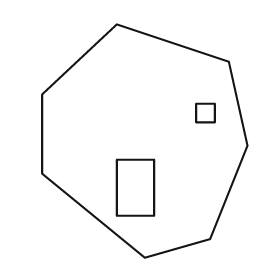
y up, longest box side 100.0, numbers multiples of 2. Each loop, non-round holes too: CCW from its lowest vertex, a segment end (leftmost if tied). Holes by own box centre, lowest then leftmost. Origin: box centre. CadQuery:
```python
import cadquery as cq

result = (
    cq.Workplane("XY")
    .moveTo(0.0, -50.0)
    .lineTo(28.0, -42.0)
    .lineTo(44.0, -2.0)
    .lineTo(36.0, 34.0)
    .lineTo(-12.0, 50.0)
    .lineTo(-44.0, 20.0)
    .lineTo(-44.0, -14.0)
    .close()
    .moveTo(-12.0, -32.0)
    .lineTo(4.0, -32.0)
    .lineTo(4.0, -8.0)
    .lineTo(-12.0, -8.0)
    .close()
    .moveTo(22.0, 8.0)
    .lineTo(30.0, 8.0)
    .lineTo(30.0, 16.0)
    .lineTo(22.0, 16.0)
    .close()
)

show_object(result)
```